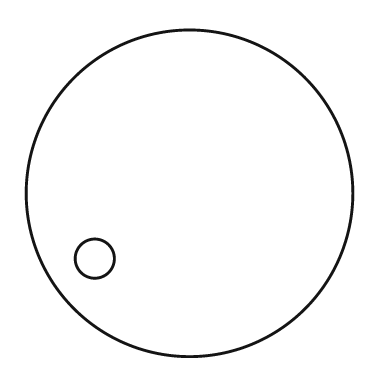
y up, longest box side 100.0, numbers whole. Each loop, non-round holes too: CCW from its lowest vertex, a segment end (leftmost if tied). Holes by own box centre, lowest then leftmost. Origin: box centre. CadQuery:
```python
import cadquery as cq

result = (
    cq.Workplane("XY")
    .moveTo(0.0, 0.0)
    .circle(50.0)
    .moveTo(-29.0, -20.0)
    .circle(6.0)
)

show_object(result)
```